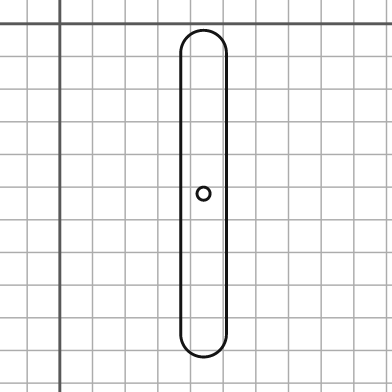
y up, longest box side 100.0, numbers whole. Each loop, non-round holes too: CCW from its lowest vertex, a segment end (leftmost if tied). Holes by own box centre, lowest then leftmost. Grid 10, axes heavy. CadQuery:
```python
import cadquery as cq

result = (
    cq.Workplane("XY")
    .moveTo(37.0, -95.0)
    .threePointArc((44.0, -102.0), (51.0, -95.0))
    .lineTo(51.0, -9.0)
    .threePointArc((44.0, -2.0), (37.0, -9.0))
    .close()
    .moveTo(44.0, -52.0)
    .circle(2.0)
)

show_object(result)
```